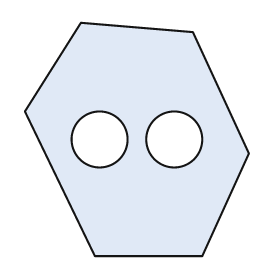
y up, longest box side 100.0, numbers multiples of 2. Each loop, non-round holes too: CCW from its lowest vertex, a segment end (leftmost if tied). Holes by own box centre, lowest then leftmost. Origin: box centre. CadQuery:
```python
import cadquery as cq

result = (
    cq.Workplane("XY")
    .moveTo(-18.0, -50.0)
    .lineTo(28.0, -50.0)
    .lineTo(48.0, -6.0)
    .lineTo(24.0, 46.0)
    .lineTo(-24.0, 50.0)
    .lineTo(-48.0, 12.0)
    .close()
    .moveTo(-16.0, 0.0)
    .circle(12.0)
    .moveTo(16.0, 0.0)
    .circle(12.0)
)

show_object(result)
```